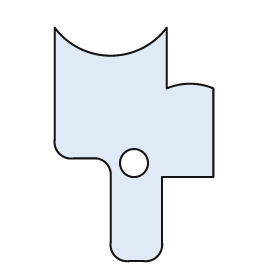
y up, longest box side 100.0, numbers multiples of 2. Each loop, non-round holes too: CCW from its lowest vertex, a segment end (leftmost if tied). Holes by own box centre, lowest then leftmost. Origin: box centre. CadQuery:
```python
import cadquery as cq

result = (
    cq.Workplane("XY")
    .moveTo(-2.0, -50.0)
    .lineTo(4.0, -50.0)
    .threePointArc((10.0, -48.0), (12.0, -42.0))
    .lineTo(12.0, -14.0)
    .lineTo(34.0, -14.0)
    .lineTo(34.0, 24.0)
    .threePointArc((24.0, 26.0), (14.0, 24.0))
    .lineTo(14.0, 50.0)
    .threePointArc((-10.0, 38.0), (-34.0, 50.0))
    .lineTo(-34.0, 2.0)
    .threePointArc((-32.0, -4.0), (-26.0, -6.0))
    .lineTo(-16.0, -6.0)
    .threePointArc((-12.0, -8.0), (-10.0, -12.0))
    .lineTo(-10.0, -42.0)
    .threePointArc((-8.0, -48.0), (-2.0, -50.0))
    .close()
    .moveTo(0.0, -8.0)
    .circle(6.0)
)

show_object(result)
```